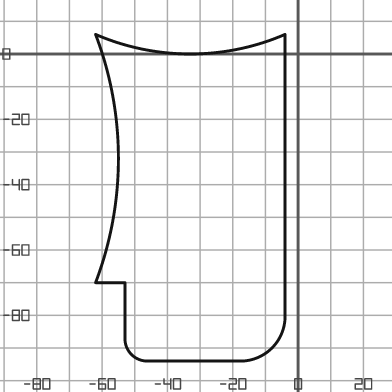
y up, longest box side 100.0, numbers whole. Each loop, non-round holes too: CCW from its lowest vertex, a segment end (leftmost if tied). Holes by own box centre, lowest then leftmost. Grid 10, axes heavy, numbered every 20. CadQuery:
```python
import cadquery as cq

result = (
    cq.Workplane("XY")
    .moveTo(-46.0, -94.0)
    .lineTo(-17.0, -94.0)
    .threePointArc((-8.0, -90.0), (-4.0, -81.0))
    .lineTo(-4.0, 6.0)
    .threePointArc((-33.0, 0.0), (-62.0, 6.0))
    .threePointArc((-55.0, -32.0), (-62.0, -70.0))
    .lineTo(-53.0, -70.0)
    .lineTo(-53.0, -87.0)
    .threePointArc((-51.0, -92.0), (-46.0, -94.0))
    .close()
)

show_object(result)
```